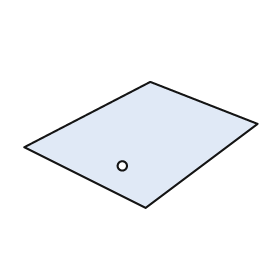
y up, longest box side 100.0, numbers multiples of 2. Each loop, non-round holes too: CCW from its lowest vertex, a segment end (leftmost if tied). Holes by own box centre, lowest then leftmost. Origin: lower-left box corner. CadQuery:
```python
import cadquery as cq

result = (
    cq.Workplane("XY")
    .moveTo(52.0, 0.0)
    .lineTo(100.0, 36.0)
    .lineTo(54.0, 54.0)
    .lineTo(0.0, 26.0)
    .close()
    .moveTo(42.0, 18.0)
    .circle(2.0)
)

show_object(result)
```